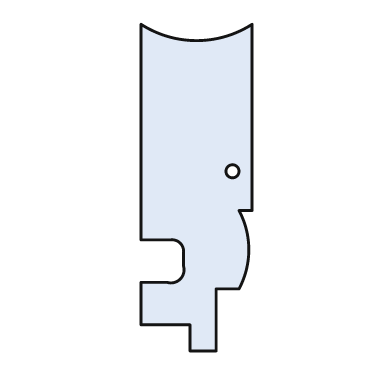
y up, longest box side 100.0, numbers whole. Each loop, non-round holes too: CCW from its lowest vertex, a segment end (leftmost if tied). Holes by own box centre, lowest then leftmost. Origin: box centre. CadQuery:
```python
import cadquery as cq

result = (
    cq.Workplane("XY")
    .moveTo(-2.0, -50.0)
    .lineTo(6.0, -50.0)
    .lineTo(6.0, -31.0)
    .lineTo(13.0, -31.0)
    .threePointArc((16.0, -19.0), (13.0, -7.0))
    .lineTo(17.0, -7.0)
    .lineTo(17.0, 50.0)
    .threePointArc((0.0, 45.0), (-17.0, 50.0))
    .lineTo(-17.0, -16.0)
    .lineTo(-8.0, -16.0)
    .threePointArc((-5.0, -17.0), (-4.0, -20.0))
    .lineTo(-4.0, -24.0)
    .threePointArc((-5.0, -28.0), (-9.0, -29.0))
    .lineTo(-17.0, -29.0)
    .lineTo(-17.0, -42.0)
    .lineTo(-2.0, -42.0)
    .close()
    .moveTo(11.0, 5.0)
    .circle(2.0)
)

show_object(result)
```